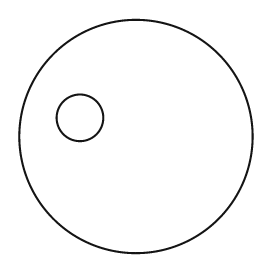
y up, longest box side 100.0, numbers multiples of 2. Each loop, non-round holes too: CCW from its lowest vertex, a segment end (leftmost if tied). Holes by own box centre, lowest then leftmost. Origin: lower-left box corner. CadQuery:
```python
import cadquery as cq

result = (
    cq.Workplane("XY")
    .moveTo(50.0, 50.0)
    .circle(50.0)
    .moveTo(26.0, 58.0)
    .circle(10.0)
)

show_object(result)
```